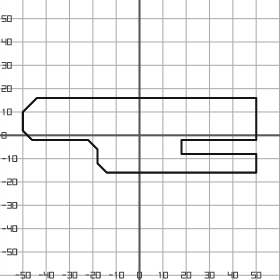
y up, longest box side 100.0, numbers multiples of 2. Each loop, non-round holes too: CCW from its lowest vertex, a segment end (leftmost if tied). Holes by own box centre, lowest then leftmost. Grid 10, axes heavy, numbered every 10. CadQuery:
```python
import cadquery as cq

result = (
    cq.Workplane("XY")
    .moveTo(-14.0, -16.0)
    .lineTo(50.0, -16.0)
    .lineTo(50.0, -8.0)
    .lineTo(18.0, -8.0)
    .lineTo(18.0, -2.0)
    .lineTo(50.0, -2.0)
    .lineTo(50.0, 16.0)
    .lineTo(-44.0, 16.0)
    .lineTo(-50.0, 10.0)
    .lineTo(-50.0, 2.0)
    .lineTo(-46.0, -2.0)
    .lineTo(-22.0, -2.0)
    .lineTo(-18.0, -6.0)
    .lineTo(-18.0, -12.0)
    .close()
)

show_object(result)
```